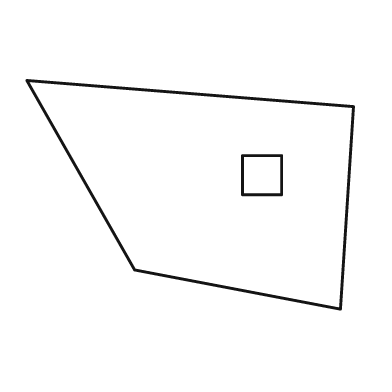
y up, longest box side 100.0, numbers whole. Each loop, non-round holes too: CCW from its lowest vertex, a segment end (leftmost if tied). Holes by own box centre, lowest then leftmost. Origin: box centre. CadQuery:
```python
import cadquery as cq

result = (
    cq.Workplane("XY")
    .moveTo(46.0, -35.0)
    .lineTo(50.0, 27.0)
    .lineTo(-50.0, 35.0)
    .lineTo(-17.0, -23.0)
    .close()
    .moveTo(16.0, 0.0)
    .lineTo(28.0, 0.0)
    .lineTo(28.0, 12.0)
    .lineTo(16.0, 12.0)
    .close()
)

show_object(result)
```